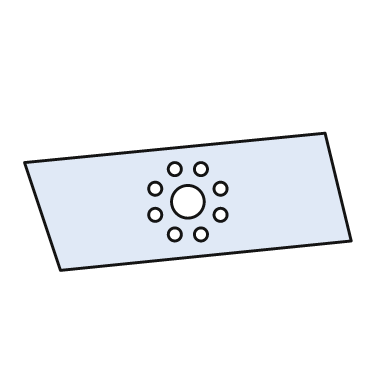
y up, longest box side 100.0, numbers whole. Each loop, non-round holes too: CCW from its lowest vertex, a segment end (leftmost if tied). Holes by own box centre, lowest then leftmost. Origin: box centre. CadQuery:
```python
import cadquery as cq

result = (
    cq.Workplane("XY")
    .moveTo(-39.0, -21.0)
    .lineTo(50.0, -12.0)
    .lineTo(42.0, 21.0)
    .lineTo(-50.0, 12.0)
    .close()
    .moveTo(-4.0, -10.0)
    .circle(2.0)
    .moveTo(4.0, -10.0)
    .circle(2.0)
    .moveTo(-10.0, -4.0)
    .circle(2.0)
    .moveTo(10.0, -4.0)
    .circle(2.0)
    .moveTo(0.0, 0.0)
    .circle(5.0)
    .moveTo(-10.0, 4.0)
    .circle(2.0)
    .moveTo(10.0, 4.0)
    .circle(2.0)
    .moveTo(-4.0, 10.0)
    .circle(2.0)
    .moveTo(4.0, 10.0)
    .circle(2.0)
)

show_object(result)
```